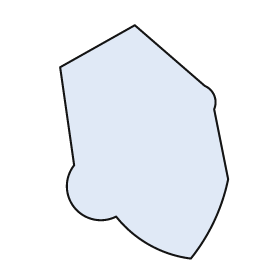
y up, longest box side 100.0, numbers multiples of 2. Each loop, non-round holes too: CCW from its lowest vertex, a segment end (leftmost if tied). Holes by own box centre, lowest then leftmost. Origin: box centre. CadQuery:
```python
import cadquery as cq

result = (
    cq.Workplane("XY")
    .moveTo(20.0, -50.0)
    .threePointArc((30.0, -34.0), (36.0, -16.0))
    .lineTo(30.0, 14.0)
    .threePointArc((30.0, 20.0), (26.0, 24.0))
    .lineTo(-4.0, 50.0)
    .lineTo(-36.0, 32.0)
    .lineTo(-30.0, -10.0)
    .threePointArc((-30.0, -28.0), (-12.0, -32.0))
    .threePointArc((2.0, -44.0), (20.0, -50.0))
    .close()
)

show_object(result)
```